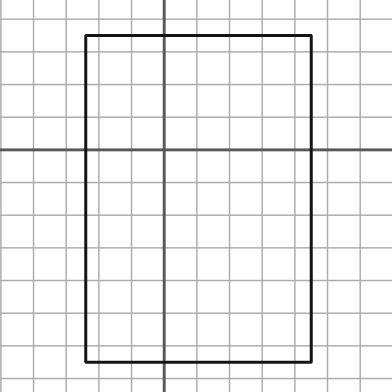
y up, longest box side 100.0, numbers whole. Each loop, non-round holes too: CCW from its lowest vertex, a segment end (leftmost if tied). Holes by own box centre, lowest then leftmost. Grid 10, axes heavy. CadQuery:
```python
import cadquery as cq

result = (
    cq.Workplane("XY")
    .moveTo(-24.0, -65.0)
    .lineTo(45.0, -65.0)
    .lineTo(45.0, 35.0)
    .lineTo(-24.0, 35.0)
    .close()
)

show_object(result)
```